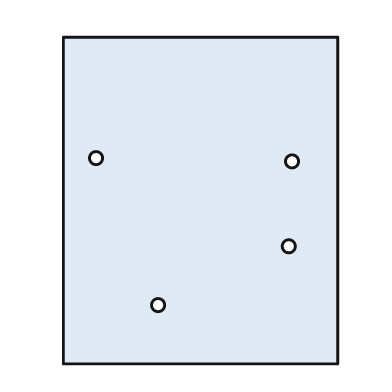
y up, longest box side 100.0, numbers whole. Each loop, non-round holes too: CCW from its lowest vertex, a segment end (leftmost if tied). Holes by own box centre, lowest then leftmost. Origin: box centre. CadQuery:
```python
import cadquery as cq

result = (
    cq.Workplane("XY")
    .moveTo(-42.0, -50.0)
    .lineTo(42.0, -50.0)
    .lineTo(42.0, 50.0)
    .lineTo(-42.0, 50.0)
    .close()
    .moveTo(-13.0, -32.0)
    .circle(2.0)
    .moveTo(27.0, -14.0)
    .circle(2.0)
    .moveTo(28.0, 12.0)
    .circle(2.0)
    .moveTo(-32.0, 13.0)
    .circle(2.0)
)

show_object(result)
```